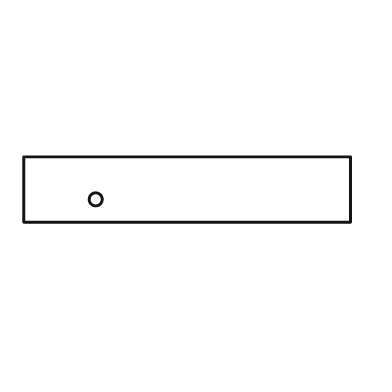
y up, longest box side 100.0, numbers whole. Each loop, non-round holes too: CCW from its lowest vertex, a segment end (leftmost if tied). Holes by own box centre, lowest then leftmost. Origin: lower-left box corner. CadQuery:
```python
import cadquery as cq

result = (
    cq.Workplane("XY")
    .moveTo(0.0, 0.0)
    .lineTo(100.0, 0.0)
    .lineTo(100.0, 20.0)
    .lineTo(0.0, 20.0)
    .close()
    .moveTo(22.0, 7.0)
    .circle(2.0)
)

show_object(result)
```